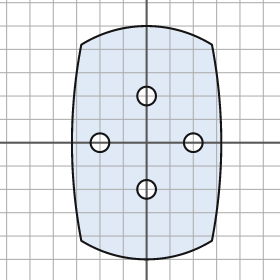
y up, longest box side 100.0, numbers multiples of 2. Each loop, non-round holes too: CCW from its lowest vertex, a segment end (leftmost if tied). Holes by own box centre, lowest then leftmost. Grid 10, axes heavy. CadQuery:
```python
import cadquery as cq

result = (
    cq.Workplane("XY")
    .moveTo(-28.0, -42.0)
    .threePointArc((0.0, -50.0), (28.0, -42.0))
    .threePointArc((32.0, 0.0), (28.0, 42.0))
    .threePointArc((0.0, 50.0), (-28.0, 42.0))
    .threePointArc((-32.0, 0.0), (-28.0, -42.0))
    .close()
    .moveTo(0.0, -20.0)
    .circle(4.0)
    .moveTo(-20.0, 0.0)
    .circle(4.0)
    .moveTo(20.0, 0.0)
    .circle(4.0)
    .moveTo(0.0, 20.0)
    .circle(4.0)
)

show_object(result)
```